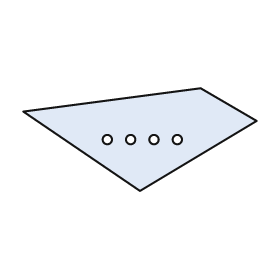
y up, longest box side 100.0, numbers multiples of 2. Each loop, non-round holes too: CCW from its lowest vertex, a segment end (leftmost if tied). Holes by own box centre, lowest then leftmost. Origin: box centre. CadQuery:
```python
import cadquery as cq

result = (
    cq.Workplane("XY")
    .moveTo(0.0, -22.0)
    .lineTo(50.0, 8.0)
    .lineTo(26.0, 22.0)
    .lineTo(-50.0, 12.0)
    .close()
    .moveTo(-14.0, 0.0)
    .circle(2.0)
    .moveTo(-4.0, 0.0)
    .circle(2.0)
    .moveTo(6.0, 0.0)
    .circle(2.0)
    .moveTo(16.0, 0.0)
    .circle(2.0)
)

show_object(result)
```